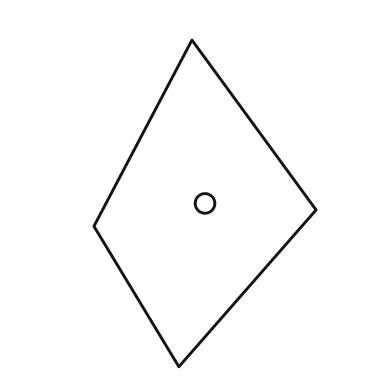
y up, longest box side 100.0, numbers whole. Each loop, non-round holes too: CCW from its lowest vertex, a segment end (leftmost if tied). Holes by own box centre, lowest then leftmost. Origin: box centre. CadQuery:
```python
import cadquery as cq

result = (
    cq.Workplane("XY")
    .moveTo(-8.0, -50.0)
    .lineTo(34.0, -2.0)
    .lineTo(-4.0, 50.0)
    .lineTo(-34.0, -7.0)
    .close()
    .moveTo(0.0, 0.0)
    .circle(3.0)
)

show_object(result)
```